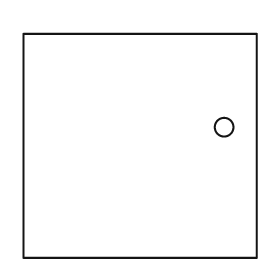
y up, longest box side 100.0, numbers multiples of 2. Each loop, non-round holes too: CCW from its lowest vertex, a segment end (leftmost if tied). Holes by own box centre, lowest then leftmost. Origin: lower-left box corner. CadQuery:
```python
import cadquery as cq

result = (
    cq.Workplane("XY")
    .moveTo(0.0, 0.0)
    .lineTo(100.0, 0.0)
    .lineTo(100.0, 96.0)
    .lineTo(0.0, 96.0)
    .close()
    .moveTo(86.0, 56.0)
    .circle(4.0)
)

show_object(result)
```